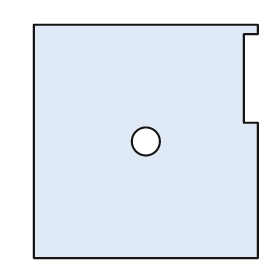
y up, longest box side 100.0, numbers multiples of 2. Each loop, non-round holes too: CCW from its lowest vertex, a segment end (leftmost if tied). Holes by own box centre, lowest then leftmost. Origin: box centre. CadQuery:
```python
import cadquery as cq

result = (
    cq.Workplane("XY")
    .moveTo(-48.0, -50.0)
    .lineTo(48.0, -50.0)
    .lineTo(48.0, 8.0)
    .lineTo(42.0, 8.0)
    .lineTo(42.0, 46.0)
    .lineTo(48.0, 46.0)
    .lineTo(48.0, 50.0)
    .lineTo(-48.0, 50.0)
    .close()
    .moveTo(0.0, 0.0)
    .circle(6.0)
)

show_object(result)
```